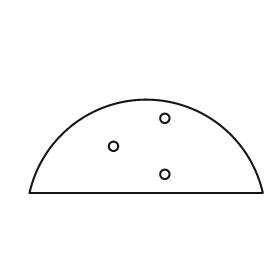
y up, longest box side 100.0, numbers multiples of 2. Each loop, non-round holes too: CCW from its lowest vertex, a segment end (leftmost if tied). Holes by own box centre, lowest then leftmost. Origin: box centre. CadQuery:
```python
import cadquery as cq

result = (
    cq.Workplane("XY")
    .moveTo(-50.0, -20.0)
    .lineTo(50.0, -20.0)
    .threePointArc((0.0, 20.0), (-50.0, -20.0))
    .close()
    .moveTo(8.0, -12.0)
    .circle(2.0)
    .moveTo(-14.0, 0.0)
    .circle(2.0)
    .moveTo(8.0, 12.0)
    .circle(2.0)
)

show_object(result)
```